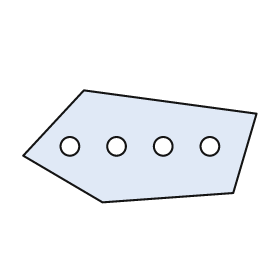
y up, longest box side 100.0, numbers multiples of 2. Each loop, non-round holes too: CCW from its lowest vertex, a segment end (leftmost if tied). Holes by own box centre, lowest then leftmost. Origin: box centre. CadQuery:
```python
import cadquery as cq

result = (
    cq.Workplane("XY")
    .moveTo(-16.0, -24.0)
    .lineTo(40.0, -20.0)
    .lineTo(50.0, 14.0)
    .lineTo(-24.0, 24.0)
    .lineTo(-50.0, -4.0)
    .close()
    .moveTo(-30.0, 0.0)
    .circle(4.0)
    .moveTo(-10.0, 0.0)
    .circle(4.0)
    .moveTo(10.0, 0.0)
    .circle(4.0)
    .moveTo(30.0, 0.0)
    .circle(4.0)
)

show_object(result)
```